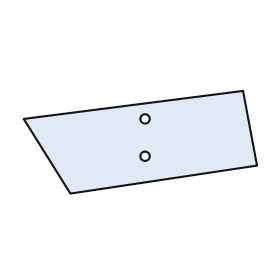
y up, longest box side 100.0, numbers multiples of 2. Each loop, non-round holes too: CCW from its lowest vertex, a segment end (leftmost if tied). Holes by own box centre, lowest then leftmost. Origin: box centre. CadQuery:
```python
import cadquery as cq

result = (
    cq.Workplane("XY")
    .moveTo(-30.0, -22.0)
    .lineTo(50.0, -10.0)
    .lineTo(44.0, 22.0)
    .lineTo(-50.0, 10.0)
    .close()
    .moveTo(2.0, -6.0)
    .circle(2.0)
    .moveTo(2.0, 10.0)
    .circle(2.0)
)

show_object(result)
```